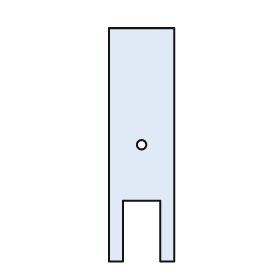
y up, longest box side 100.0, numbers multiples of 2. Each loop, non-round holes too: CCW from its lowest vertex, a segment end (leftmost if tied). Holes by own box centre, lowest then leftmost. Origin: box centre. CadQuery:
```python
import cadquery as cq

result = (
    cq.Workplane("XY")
    .moveTo(-14.0, -50.0)
    .lineTo(-8.0, -50.0)
    .lineTo(-8.0, -24.0)
    .lineTo(8.0, -24.0)
    .lineTo(8.0, -50.0)
    .lineTo(14.0, -50.0)
    .lineTo(14.0, 50.0)
    .lineTo(-14.0, 50.0)
    .close()
    .moveTo(0.0, 0.0)
    .circle(2.0)
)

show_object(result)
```